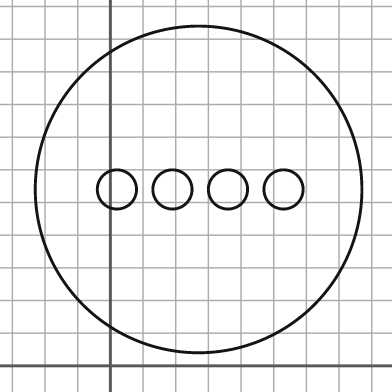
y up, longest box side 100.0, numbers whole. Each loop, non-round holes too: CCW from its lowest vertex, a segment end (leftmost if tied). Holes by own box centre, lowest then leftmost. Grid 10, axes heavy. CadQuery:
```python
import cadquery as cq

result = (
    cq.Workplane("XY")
    .moveTo(27.0, 54.0)
    .circle(50.0)
    .moveTo(2.0, 54.0)
    .circle(6.0)
    .moveTo(19.0, 54.0)
    .circle(6.0)
    .moveTo(36.0, 54.0)
    .circle(6.0)
    .moveTo(53.0, 54.0)
    .circle(6.0)
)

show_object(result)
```